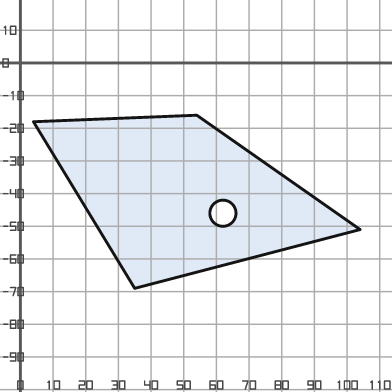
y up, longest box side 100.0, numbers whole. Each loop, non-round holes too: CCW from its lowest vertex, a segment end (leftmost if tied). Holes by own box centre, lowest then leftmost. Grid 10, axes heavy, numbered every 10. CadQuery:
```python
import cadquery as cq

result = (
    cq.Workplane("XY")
    .moveTo(35.0, -69.0)
    .lineTo(104.0, -51.0)
    .lineTo(54.0, -16.0)
    .lineTo(4.0, -18.0)
    .close()
    .moveTo(62.0, -46.0)
    .circle(4.0)
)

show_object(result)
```